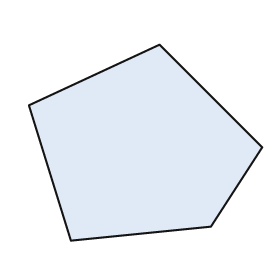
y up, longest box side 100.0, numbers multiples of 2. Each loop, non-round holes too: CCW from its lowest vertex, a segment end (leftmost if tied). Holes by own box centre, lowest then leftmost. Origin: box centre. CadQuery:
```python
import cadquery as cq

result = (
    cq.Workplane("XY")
    .moveTo(-32.0, -42.0)
    .lineTo(28.0, -36.0)
    .lineTo(50.0, -2.0)
    .lineTo(6.0, 42.0)
    .lineTo(-50.0, 16.0)
    .close()
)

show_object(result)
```